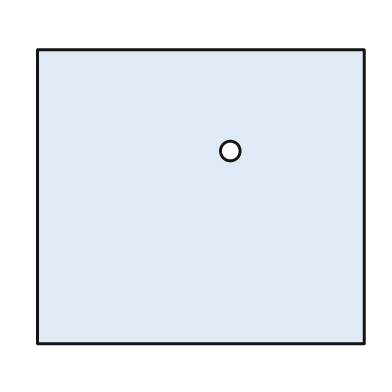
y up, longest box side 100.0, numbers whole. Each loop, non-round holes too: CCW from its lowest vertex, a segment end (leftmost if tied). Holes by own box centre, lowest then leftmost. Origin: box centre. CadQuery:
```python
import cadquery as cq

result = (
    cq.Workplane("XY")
    .moveTo(-50.0, -45.0)
    .lineTo(50.0, -45.0)
    .lineTo(50.0, 45.0)
    .lineTo(-50.0, 45.0)
    .close()
    .moveTo(9.0, 14.0)
    .circle(3.0)
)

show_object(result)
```